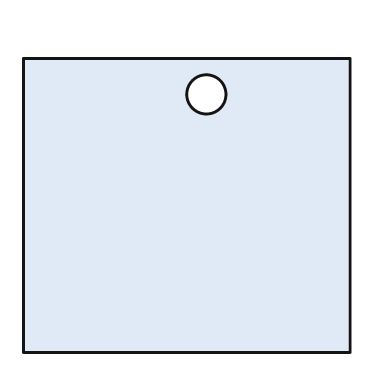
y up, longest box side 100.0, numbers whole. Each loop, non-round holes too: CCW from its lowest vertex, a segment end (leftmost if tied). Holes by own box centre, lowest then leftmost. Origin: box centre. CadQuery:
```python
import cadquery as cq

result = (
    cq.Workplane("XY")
    .moveTo(-50.0, -45.0)
    .lineTo(50.0, -45.0)
    .lineTo(50.0, 45.0)
    .lineTo(-50.0, 45.0)
    .close()
    .moveTo(6.0, 34.0)
    .circle(6.0)
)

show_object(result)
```